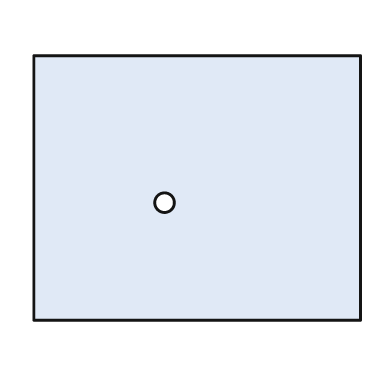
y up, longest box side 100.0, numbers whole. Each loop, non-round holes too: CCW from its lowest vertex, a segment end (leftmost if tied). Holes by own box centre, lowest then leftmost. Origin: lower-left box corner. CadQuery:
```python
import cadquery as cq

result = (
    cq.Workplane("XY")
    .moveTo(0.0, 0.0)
    .lineTo(100.0, 0.0)
    .lineTo(100.0, 81.0)
    .lineTo(0.0, 81.0)
    .close()
    .moveTo(40.0, 36.0)
    .circle(3.0)
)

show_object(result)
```